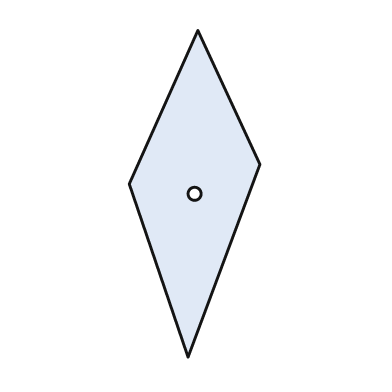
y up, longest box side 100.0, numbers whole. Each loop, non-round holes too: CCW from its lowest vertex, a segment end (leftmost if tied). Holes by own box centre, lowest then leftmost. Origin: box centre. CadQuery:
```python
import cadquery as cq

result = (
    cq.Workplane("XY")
    .moveTo(-2.0, -50.0)
    .lineTo(20.0, 9.0)
    .lineTo(1.0, 50.0)
    .lineTo(-20.0, 3.0)
    .close()
    .moveTo(0.0, 0.0)
    .circle(2.0)
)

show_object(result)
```